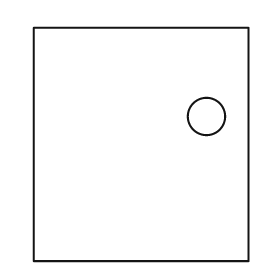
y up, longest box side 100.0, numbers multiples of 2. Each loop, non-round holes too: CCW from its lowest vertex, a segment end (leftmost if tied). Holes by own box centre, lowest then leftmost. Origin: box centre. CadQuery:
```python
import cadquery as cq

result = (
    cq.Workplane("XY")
    .moveTo(-46.0, -50.0)
    .lineTo(46.0, -50.0)
    .lineTo(46.0, 50.0)
    .lineTo(-46.0, 50.0)
    .close()
    .moveTo(28.0, 12.0)
    .circle(8.0)
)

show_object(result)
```